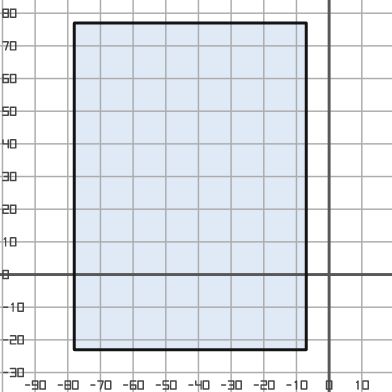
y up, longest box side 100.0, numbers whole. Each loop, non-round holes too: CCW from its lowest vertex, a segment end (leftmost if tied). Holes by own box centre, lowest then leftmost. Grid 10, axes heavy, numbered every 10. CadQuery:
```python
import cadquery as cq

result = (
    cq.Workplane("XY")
    .moveTo(-78.0, -23.0)
    .lineTo(-7.0, -23.0)
    .lineTo(-7.0, 77.0)
    .lineTo(-78.0, 77.0)
    .close()
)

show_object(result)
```